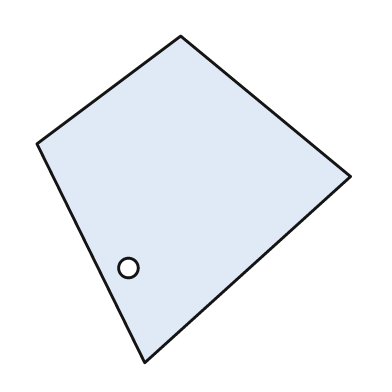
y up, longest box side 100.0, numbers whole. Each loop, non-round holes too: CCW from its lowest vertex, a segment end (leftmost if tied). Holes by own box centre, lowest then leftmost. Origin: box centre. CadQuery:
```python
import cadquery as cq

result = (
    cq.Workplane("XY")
    .moveTo(-15.0, -50.0)
    .lineTo(48.0, 7.0)
    .lineTo(-4.0, 50.0)
    .lineTo(-48.0, 17.0)
    .close()
    .moveTo(-20.0, -21.0)
    .circle(3.0)
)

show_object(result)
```